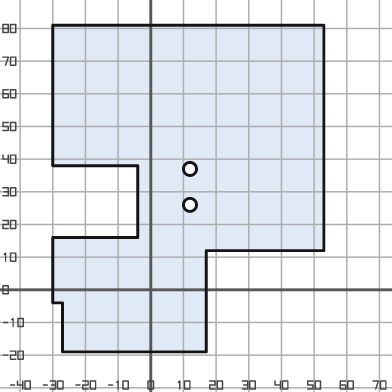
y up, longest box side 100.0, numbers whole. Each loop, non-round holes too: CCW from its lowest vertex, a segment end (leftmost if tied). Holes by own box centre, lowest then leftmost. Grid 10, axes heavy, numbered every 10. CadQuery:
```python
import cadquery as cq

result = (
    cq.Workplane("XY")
    .moveTo(-27.0, -19.0)
    .lineTo(17.0, -19.0)
    .lineTo(17.0, 12.0)
    .lineTo(53.0, 12.0)
    .lineTo(53.0, 81.0)
    .lineTo(-30.0, 81.0)
    .lineTo(-30.0, 38.0)
    .lineTo(-4.0, 38.0)
    .lineTo(-4.0, 16.0)
    .lineTo(-30.0, 16.0)
    .lineTo(-30.0, -4.0)
    .lineTo(-27.0, -4.0)
    .close()
    .moveTo(12.0, 26.0)
    .circle(2.0)
    .moveTo(12.0, 37.0)
    .circle(2.0)
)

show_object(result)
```